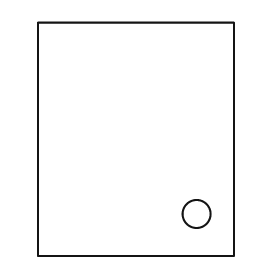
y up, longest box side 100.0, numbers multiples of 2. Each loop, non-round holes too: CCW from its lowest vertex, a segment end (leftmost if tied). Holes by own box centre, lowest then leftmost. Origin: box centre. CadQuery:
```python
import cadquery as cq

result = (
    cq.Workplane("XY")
    .moveTo(-42.0, -50.0)
    .lineTo(42.0, -50.0)
    .lineTo(42.0, 50.0)
    .lineTo(-42.0, 50.0)
    .close()
    .moveTo(26.0, -32.0)
    .circle(6.0)
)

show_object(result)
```